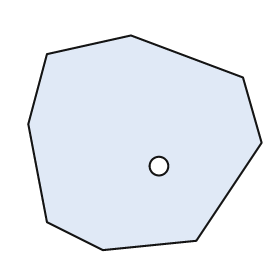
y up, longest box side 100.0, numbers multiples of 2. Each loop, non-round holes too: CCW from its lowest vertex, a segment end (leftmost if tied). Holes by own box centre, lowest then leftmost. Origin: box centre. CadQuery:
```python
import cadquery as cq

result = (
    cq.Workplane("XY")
    .moveTo(-18.0, -46.0)
    .lineTo(22.0, -42.0)
    .lineTo(50.0, 0.0)
    .lineTo(42.0, 28.0)
    .lineTo(-6.0, 46.0)
    .lineTo(-42.0, 38.0)
    .lineTo(-50.0, 8.0)
    .lineTo(-42.0, -34.0)
    .close()
    .moveTo(6.0, -10.0)
    .circle(4.0)
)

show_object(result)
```